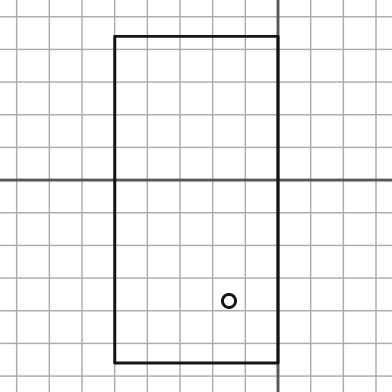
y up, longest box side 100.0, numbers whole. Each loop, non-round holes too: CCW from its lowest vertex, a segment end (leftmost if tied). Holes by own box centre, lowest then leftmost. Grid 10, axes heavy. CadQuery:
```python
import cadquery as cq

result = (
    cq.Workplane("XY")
    .moveTo(-50.0, -56.0)
    .lineTo(0.0, -56.0)
    .lineTo(0.0, 44.0)
    .lineTo(-50.0, 44.0)
    .close()
    .moveTo(-15.0, -37.0)
    .circle(2.0)
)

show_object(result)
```